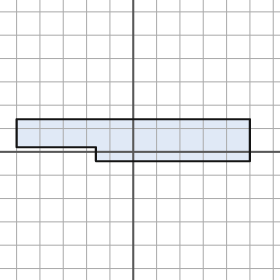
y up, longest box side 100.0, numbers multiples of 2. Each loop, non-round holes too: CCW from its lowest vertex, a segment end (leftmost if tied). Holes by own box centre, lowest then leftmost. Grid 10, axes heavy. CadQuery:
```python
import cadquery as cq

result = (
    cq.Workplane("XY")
    .moveTo(-16.0, -4.0)
    .lineTo(50.0, -4.0)
    .lineTo(50.0, 14.0)
    .lineTo(-50.0, 14.0)
    .lineTo(-50.0, 2.0)
    .lineTo(-16.0, 2.0)
    .close()
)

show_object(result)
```